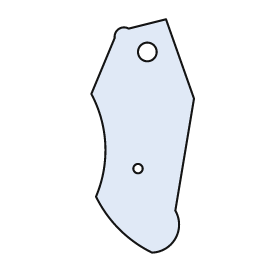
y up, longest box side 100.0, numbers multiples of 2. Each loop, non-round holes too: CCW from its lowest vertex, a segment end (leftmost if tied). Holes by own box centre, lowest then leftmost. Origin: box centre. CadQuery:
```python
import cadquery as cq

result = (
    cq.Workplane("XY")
    .moveTo(4.0, -50.0)
    .threePointArc((14.0, -44.0), (14.0, -32.0))
    .lineTo(22.0, 16.0)
    .lineTo(10.0, 50.0)
    .lineTo(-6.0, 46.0)
    .threePointArc((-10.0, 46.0), (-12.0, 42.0))
    .lineTo(-22.0, 18.0)
    .threePointArc((-16.0, -4.0), (-20.0, -26.0))
    .threePointArc((-10.0, -40.0), (4.0, -50.0))
    .close()
    .moveTo(-2.0, -14.0)
    .circle(2.0)
    .moveTo(2.0, 36.0)
    .circle(4.0)
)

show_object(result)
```